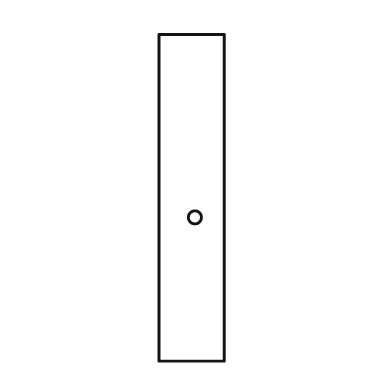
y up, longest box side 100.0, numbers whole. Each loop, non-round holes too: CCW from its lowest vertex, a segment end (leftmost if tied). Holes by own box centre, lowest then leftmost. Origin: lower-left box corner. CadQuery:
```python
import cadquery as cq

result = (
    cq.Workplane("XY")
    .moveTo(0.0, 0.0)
    .lineTo(20.0, 0.0)
    .lineTo(20.0, 100.0)
    .lineTo(0.0, 100.0)
    .close()
    .moveTo(11.0, 44.0)
    .circle(2.0)
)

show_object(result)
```